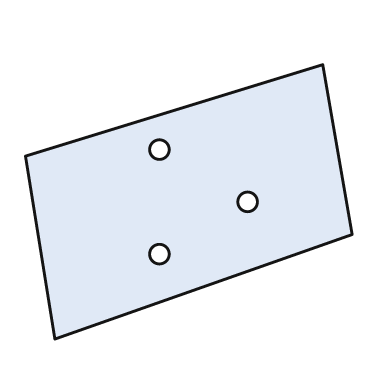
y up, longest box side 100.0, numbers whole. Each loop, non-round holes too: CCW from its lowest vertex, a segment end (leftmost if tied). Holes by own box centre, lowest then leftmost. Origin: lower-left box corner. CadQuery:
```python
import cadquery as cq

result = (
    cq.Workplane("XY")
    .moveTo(9.0, 0.0)
    .lineTo(100.0, 32.0)
    .lineTo(91.0, 84.0)
    .lineTo(0.0, 56.0)
    .close()
    .moveTo(41.0, 26.0)
    .circle(3.0)
    .moveTo(68.0, 42.0)
    .circle(3.0)
    .moveTo(41.0, 58.0)
    .circle(3.0)
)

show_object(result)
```